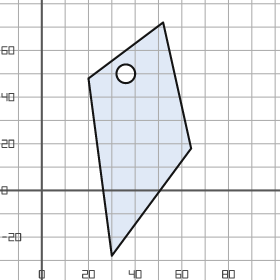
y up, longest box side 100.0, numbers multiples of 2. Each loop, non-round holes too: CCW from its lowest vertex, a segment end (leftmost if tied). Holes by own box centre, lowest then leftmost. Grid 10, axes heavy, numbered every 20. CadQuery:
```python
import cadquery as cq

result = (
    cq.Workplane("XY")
    .moveTo(30.0, -28.0)
    .lineTo(64.0, 18.0)
    .lineTo(52.0, 72.0)
    .lineTo(20.0, 48.0)
    .close()
    .moveTo(36.0, 50.0)
    .circle(4.0)
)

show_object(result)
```